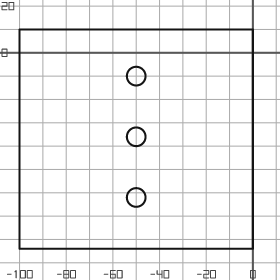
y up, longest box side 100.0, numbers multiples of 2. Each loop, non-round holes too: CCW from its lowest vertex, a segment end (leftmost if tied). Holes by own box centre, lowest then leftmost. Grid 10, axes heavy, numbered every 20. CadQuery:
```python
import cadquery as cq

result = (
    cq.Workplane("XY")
    .moveTo(-100.0, -84.0)
    .lineTo(0.0, -84.0)
    .lineTo(0.0, 10.0)
    .lineTo(-100.0, 10.0)
    .close()
    .moveTo(-50.0, -62.0)
    .circle(4.0)
    .moveTo(-50.0, -36.0)
    .circle(4.0)
    .moveTo(-50.0, -10.0)
    .circle(4.0)
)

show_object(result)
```